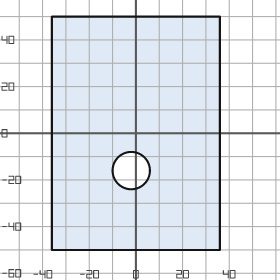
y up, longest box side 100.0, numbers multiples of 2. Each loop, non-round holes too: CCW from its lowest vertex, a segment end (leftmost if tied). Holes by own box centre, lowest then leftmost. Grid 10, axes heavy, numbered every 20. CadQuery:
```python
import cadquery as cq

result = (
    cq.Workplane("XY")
    .moveTo(-36.0, -50.0)
    .lineTo(36.0, -50.0)
    .lineTo(36.0, 50.0)
    .lineTo(-36.0, 50.0)
    .close()
    .moveTo(-2.0, -16.0)
    .circle(8.0)
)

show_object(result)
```